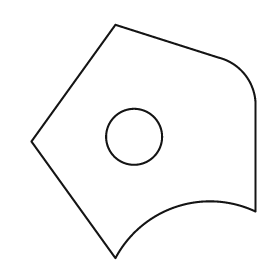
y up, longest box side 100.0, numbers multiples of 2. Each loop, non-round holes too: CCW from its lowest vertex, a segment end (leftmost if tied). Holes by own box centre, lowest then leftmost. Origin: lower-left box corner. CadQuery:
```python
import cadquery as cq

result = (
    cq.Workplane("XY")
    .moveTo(36.0, 0.0)
    .threePointArc((62.0, 22.0), (96.0, 20.0))
    .lineTo(96.0, 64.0)
    .threePointArc((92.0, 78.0), (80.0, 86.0))
    .lineTo(36.0, 100.0)
    .lineTo(0.0, 50.0)
    .close()
    .moveTo(44.0, 52.0)
    .circle(12.0)
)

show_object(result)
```